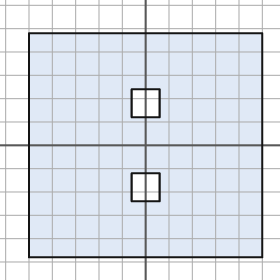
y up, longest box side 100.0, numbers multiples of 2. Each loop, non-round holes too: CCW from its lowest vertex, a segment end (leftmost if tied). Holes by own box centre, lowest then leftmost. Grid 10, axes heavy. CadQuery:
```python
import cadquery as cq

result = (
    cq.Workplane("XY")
    .moveTo(-50.0, -48.0)
    .lineTo(50.0, -48.0)
    .lineTo(50.0, 48.0)
    .lineTo(-50.0, 48.0)
    .close()
    .moveTo(-6.0, -24.0)
    .lineTo(6.0, -24.0)
    .lineTo(6.0, -12.0)
    .lineTo(-6.0, -12.0)
    .close()
    .moveTo(-6.0, 12.0)
    .lineTo(6.0, 12.0)
    .lineTo(6.0, 24.0)
    .lineTo(-6.0, 24.0)
    .close()
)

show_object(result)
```